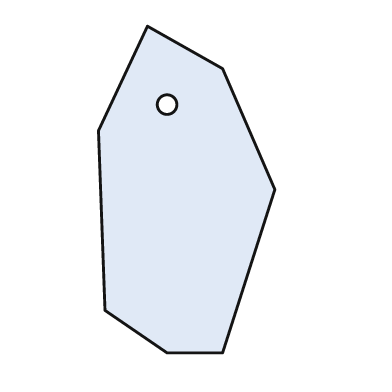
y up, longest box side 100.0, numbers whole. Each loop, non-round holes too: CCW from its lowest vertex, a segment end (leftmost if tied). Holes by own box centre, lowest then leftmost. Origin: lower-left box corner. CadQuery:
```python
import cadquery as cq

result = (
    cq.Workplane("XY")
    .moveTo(21.0, 0.0)
    .lineTo(38.0, 0.0)
    .lineTo(54.0, 50.0)
    .lineTo(38.0, 87.0)
    .lineTo(15.0, 100.0)
    .lineTo(0.0, 68.0)
    .lineTo(2.0, 13.0)
    .close()
    .moveTo(21.0, 76.0)
    .circle(3.0)
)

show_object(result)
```